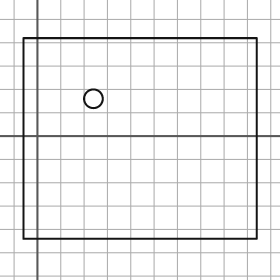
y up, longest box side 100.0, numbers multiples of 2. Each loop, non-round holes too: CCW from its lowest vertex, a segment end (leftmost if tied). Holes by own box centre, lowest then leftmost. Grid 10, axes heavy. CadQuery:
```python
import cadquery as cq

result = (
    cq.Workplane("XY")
    .moveTo(-6.0, -44.0)
    .lineTo(94.0, -44.0)
    .lineTo(94.0, 42.0)
    .lineTo(-6.0, 42.0)
    .close()
    .moveTo(24.0, 16.0)
    .circle(4.0)
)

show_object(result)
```